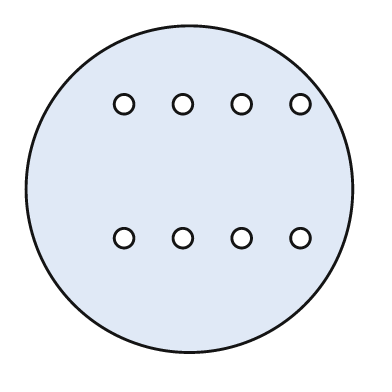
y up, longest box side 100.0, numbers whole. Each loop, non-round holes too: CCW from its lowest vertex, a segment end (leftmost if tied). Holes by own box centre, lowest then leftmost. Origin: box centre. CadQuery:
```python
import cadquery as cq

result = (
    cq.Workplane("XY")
    .moveTo(0.0, 0.0)
    .circle(50.0)
    .moveTo(-20.0, -15.0)
    .circle(3.0)
    .moveTo(-2.0, -15.0)
    .circle(3.0)
    .moveTo(16.0, -15.0)
    .circle(3.0)
    .moveTo(34.0, -15.0)
    .circle(3.0)
    .moveTo(-20.0, 26.0)
    .circle(3.0)
    .moveTo(-2.0, 26.0)
    .circle(3.0)
    .moveTo(16.0, 26.0)
    .circle(3.0)
    .moveTo(34.0, 26.0)
    .circle(3.0)
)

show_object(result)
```